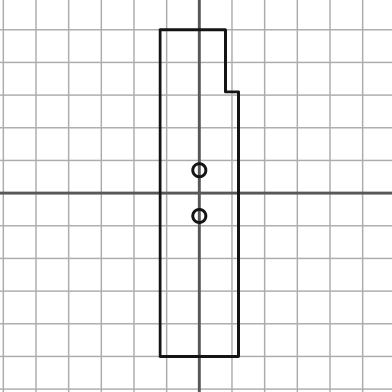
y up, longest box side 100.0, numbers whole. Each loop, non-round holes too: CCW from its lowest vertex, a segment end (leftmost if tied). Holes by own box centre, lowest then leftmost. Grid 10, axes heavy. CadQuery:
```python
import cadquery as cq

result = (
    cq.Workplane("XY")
    .moveTo(-12.0, -50.0)
    .lineTo(12.0, -50.0)
    .lineTo(12.0, 31.0)
    .lineTo(8.0, 31.0)
    .lineTo(8.0, 50.0)
    .lineTo(-12.0, 50.0)
    .close()
    .moveTo(0.0, -7.0)
    .circle(2.0)
    .moveTo(0.0, 7.0)
    .circle(2.0)
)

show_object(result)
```